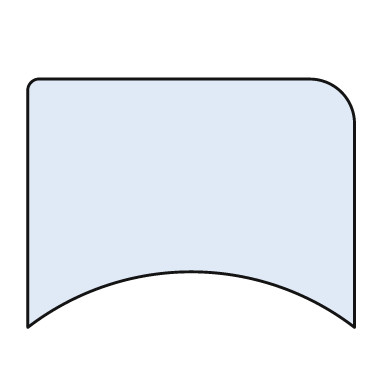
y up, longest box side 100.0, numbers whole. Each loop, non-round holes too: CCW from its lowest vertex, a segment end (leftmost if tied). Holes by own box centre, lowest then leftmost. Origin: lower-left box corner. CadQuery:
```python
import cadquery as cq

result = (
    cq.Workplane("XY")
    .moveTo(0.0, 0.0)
    .threePointArc((50.0, 17.0), (100.0, 0.0))
    .lineTo(100.0, 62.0)
    .threePointArc((96.0, 72.0), (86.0, 76.0))
    .lineTo(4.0, 76.0)
    .threePointArc((1.0, 75.0), (0.0, 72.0))
    .close()
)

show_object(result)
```